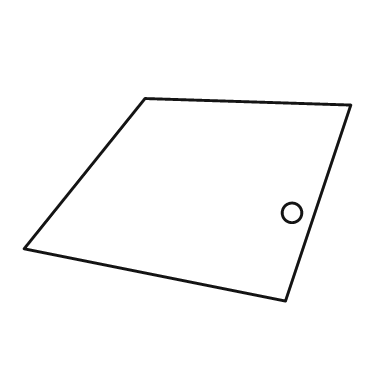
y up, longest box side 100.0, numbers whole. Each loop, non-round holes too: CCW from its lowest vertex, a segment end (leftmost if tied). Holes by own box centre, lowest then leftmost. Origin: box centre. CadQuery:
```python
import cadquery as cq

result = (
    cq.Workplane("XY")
    .moveTo(30.0, -31.0)
    .lineTo(50.0, 29.0)
    .lineTo(-13.0, 31.0)
    .lineTo(-50.0, -15.0)
    .close()
    .moveTo(32.0, -4.0)
    .circle(3.0)
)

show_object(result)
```